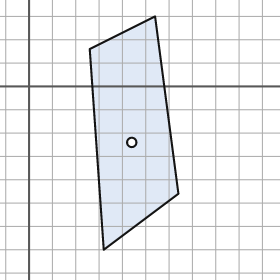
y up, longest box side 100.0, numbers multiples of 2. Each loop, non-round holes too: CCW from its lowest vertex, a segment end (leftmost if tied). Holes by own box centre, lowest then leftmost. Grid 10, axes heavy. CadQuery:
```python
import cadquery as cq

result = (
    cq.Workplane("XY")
    .moveTo(32.0, -70.0)
    .lineTo(64.0, -46.0)
    .lineTo(54.0, 30.0)
    .lineTo(26.0, 16.0)
    .close()
    .moveTo(44.0, -24.0)
    .circle(2.0)
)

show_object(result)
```